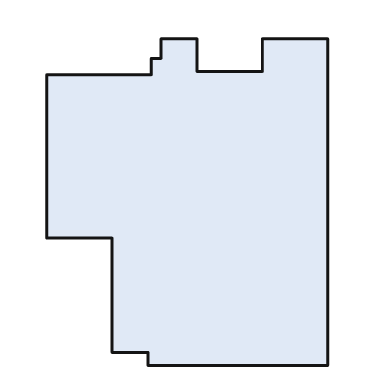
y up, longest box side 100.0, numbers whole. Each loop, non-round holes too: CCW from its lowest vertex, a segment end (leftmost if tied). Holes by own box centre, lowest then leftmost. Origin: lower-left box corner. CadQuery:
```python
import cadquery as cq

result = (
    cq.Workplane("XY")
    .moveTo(31.0, 0.0)
    .lineTo(86.0, 0.0)
    .lineTo(86.0, 100.0)
    .lineTo(66.0, 100.0)
    .lineTo(66.0, 90.0)
    .lineTo(46.0, 90.0)
    .lineTo(46.0, 100.0)
    .lineTo(35.0, 100.0)
    .lineTo(35.0, 94.0)
    .lineTo(32.0, 94.0)
    .lineTo(32.0, 89.0)
    .lineTo(0.0, 89.0)
    .lineTo(0.0, 39.0)
    .lineTo(20.0, 39.0)
    .lineTo(20.0, 4.0)
    .lineTo(31.0, 4.0)
    .close()
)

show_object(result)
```